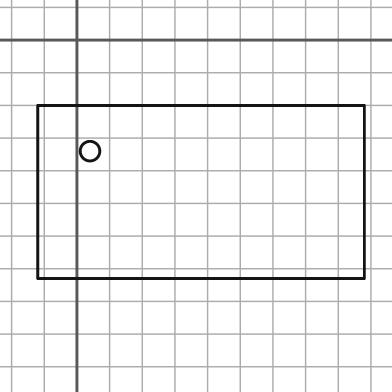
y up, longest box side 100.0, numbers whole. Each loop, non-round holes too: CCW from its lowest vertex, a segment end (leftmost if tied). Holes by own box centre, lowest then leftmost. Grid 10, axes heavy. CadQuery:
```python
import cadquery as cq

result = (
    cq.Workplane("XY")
    .moveTo(-12.0, -73.0)
    .lineTo(88.0, -73.0)
    .lineTo(88.0, -20.0)
    .lineTo(-12.0, -20.0)
    .close()
    .moveTo(4.0, -34.0)
    .circle(3.0)
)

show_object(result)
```